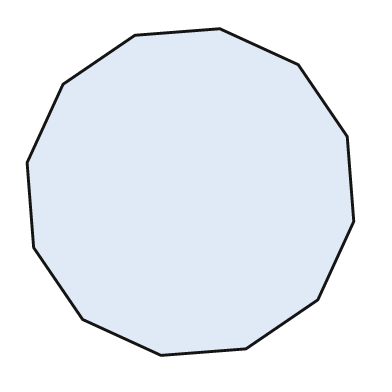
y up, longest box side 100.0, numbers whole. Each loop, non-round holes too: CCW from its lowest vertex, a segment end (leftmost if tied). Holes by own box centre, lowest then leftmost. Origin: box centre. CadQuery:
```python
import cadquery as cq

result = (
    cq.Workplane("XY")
    .moveTo(-9.0, -50.0)
    .lineTo(17.0, -48.0)
    .lineTo(39.0, -33.0)
    .lineTo(50.0, -9.0)
    .lineTo(48.0, 17.0)
    .lineTo(33.0, 39.0)
    .lineTo(9.0, 50.0)
    .lineTo(-17.0, 48.0)
    .lineTo(-39.0, 33.0)
    .lineTo(-50.0, 9.0)
    .lineTo(-48.0, -17.0)
    .lineTo(-33.0, -39.0)
    .close()
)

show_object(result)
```